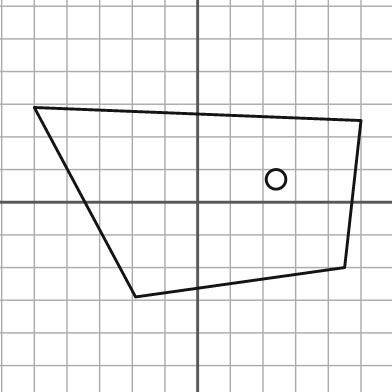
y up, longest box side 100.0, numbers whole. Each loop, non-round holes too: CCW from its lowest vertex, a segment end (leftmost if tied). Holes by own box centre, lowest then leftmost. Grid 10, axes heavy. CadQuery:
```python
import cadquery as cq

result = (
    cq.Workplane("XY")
    .moveTo(-19.0, -29.0)
    .lineTo(45.0, -20.0)
    .lineTo(50.0, 25.0)
    .lineTo(-50.0, 29.0)
    .close()
    .moveTo(24.0, 7.0)
    .circle(3.0)
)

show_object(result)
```